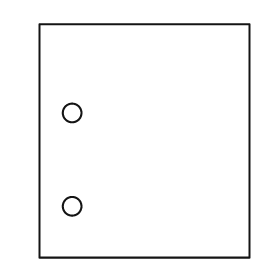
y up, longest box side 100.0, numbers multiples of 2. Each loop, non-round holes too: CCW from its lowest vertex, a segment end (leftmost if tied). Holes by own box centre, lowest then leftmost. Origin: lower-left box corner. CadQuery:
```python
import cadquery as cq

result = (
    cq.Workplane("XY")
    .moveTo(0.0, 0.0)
    .lineTo(90.0, 0.0)
    .lineTo(90.0, 100.0)
    .lineTo(0.0, 100.0)
    .close()
    .moveTo(14.0, 22.0)
    .circle(4.0)
    .moveTo(14.0, 62.0)
    .circle(4.0)
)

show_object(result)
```